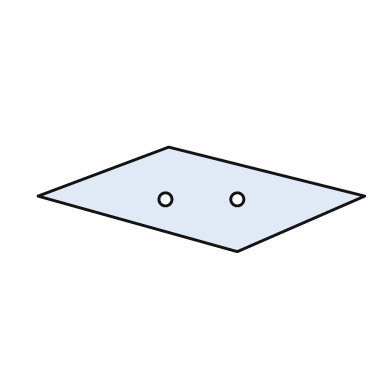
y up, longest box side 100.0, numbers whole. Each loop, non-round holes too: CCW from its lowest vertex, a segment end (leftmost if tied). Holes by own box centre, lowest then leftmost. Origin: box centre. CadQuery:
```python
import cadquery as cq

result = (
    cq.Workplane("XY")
    .moveTo(11.0, -16.0)
    .lineTo(50.0, 1.0)
    .lineTo(-10.0, 16.0)
    .lineTo(-50.0, 1.0)
    .close()
    .moveTo(-11.0, 0.0)
    .circle(2.0)
    .moveTo(11.0, 0.0)
    .circle(2.0)
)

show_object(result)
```